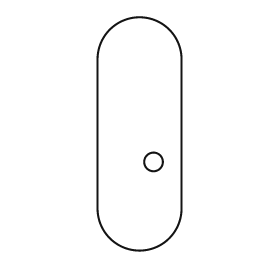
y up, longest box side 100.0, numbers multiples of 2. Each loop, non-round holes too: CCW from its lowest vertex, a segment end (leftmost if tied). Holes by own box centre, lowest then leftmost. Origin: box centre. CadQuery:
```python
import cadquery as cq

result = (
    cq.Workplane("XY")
    .moveTo(-18.0, -32.0)
    .threePointArc((0.0, -50.0), (18.0, -32.0))
    .lineTo(18.0, 32.0)
    .threePointArc((0.0, 50.0), (-18.0, 32.0))
    .close()
    .moveTo(6.0, -12.0)
    .circle(4.0)
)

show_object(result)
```